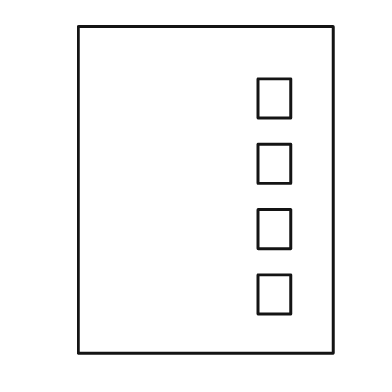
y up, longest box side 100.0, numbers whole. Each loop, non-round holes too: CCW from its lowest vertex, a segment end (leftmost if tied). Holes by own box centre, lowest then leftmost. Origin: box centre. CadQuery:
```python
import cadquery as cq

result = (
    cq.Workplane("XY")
    .moveTo(-39.0, -50.0)
    .lineTo(39.0, -50.0)
    .lineTo(39.0, 50.0)
    .lineTo(-39.0, 50.0)
    .close()
    .moveTo(16.0, -38.0)
    .lineTo(26.0, -38.0)
    .lineTo(26.0, -26.0)
    .lineTo(16.0, -26.0)
    .close()
    .moveTo(16.0, -18.0)
    .lineTo(26.0, -18.0)
    .lineTo(26.0, -6.0)
    .lineTo(16.0, -6.0)
    .close()
    .moveTo(16.0, 2.0)
    .lineTo(26.0, 2.0)
    .lineTo(26.0, 14.0)
    .lineTo(16.0, 14.0)
    .close()
    .moveTo(16.0, 22.0)
    .lineTo(26.0, 22.0)
    .lineTo(26.0, 34.0)
    .lineTo(16.0, 34.0)
    .close()
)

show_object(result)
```